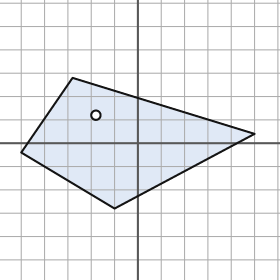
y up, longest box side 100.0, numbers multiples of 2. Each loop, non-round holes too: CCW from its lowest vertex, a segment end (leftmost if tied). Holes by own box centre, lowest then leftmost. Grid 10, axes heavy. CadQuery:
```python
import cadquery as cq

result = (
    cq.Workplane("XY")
    .moveTo(-10.0, -28.0)
    .lineTo(50.0, 4.0)
    .lineTo(-28.0, 28.0)
    .lineTo(-50.0, -4.0)
    .close()
    .moveTo(-18.0, 12.0)
    .circle(2.0)
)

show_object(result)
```